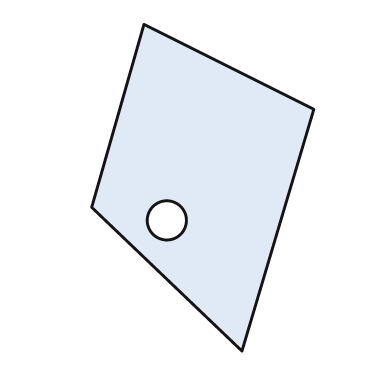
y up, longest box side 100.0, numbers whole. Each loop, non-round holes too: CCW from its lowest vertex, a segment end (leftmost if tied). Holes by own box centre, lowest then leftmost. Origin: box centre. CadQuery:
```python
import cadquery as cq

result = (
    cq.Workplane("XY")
    .moveTo(12.0, -50.0)
    .lineTo(34.0, 24.0)
    .lineTo(-18.0, 50.0)
    .lineTo(-34.0, -6.0)
    .close()
    .moveTo(-11.0, -10.0)
    .circle(6.0)
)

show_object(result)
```